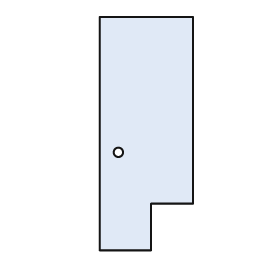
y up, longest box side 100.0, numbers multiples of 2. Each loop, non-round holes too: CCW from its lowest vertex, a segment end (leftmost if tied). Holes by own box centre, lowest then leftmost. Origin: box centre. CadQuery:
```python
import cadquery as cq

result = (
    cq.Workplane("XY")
    .moveTo(-20.0, -50.0)
    .lineTo(2.0, -50.0)
    .lineTo(2.0, -30.0)
    .lineTo(20.0, -30.0)
    .lineTo(20.0, 50.0)
    .lineTo(-20.0, 50.0)
    .close()
    .moveTo(-12.0, -8.0)
    .circle(2.0)
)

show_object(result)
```